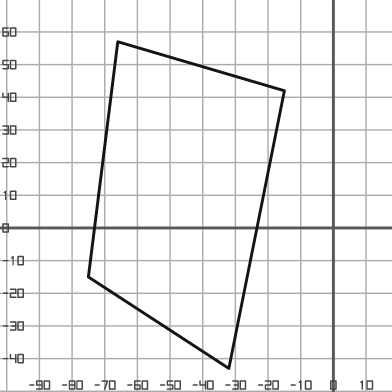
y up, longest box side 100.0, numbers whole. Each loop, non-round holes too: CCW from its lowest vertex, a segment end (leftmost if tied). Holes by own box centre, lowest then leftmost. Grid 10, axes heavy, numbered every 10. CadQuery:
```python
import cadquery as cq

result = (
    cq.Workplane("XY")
    .moveTo(-32.0, -43.0)
    .lineTo(-15.0, 42.0)
    .lineTo(-66.0, 57.0)
    .lineTo(-75.0, -15.0)
    .close()
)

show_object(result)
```